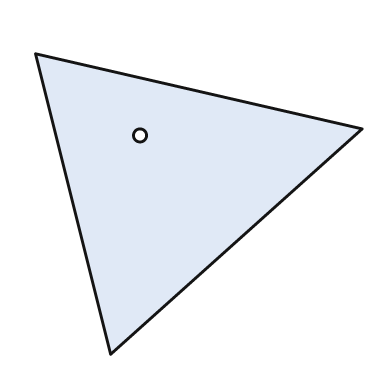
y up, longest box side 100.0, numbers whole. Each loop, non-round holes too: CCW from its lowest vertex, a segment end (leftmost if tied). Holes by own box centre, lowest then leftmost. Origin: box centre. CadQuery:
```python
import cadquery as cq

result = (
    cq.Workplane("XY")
    .moveTo(-27.0, -46.0)
    .lineTo(50.0, 23.0)
    .lineTo(-50.0, 46.0)
    .close()
    .moveTo(-18.0, 21.0)
    .circle(2.0)
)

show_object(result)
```